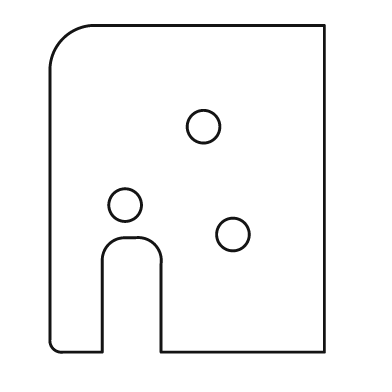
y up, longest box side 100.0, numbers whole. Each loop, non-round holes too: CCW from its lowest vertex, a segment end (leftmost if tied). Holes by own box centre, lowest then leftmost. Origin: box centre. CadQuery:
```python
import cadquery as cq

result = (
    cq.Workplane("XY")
    .moveTo(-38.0, -50.0)
    .lineTo(-26.0, -50.0)
    .lineTo(-26.0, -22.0)
    .threePointArc((-24.0, -17.0), (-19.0, -15.0))
    .lineTo(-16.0, -15.0)
    .threePointArc((-10.0, -17.0), (-8.0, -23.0))
    .lineTo(-8.0, -50.0)
    .lineTo(42.0, -50.0)
    .lineTo(42.0, 50.0)
    .lineTo(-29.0, 50.0)
    .threePointArc((-38.0, 46.0), (-42.0, 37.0))
    .lineTo(-42.0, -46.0)
    .threePointArc((-41.0, -49.0), (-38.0, -50.0))
    .close()
    .moveTo(14.0, -14.0)
    .circle(5.0)
    .moveTo(-19.0, -5.0)
    .circle(5.0)
    .moveTo(5.0, 19.0)
    .circle(5.0)
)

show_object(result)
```